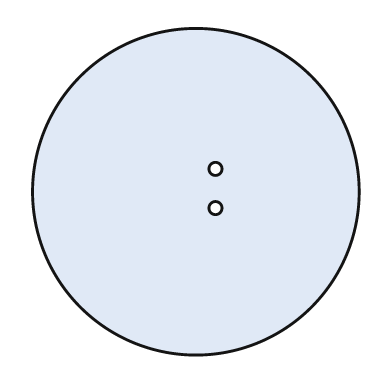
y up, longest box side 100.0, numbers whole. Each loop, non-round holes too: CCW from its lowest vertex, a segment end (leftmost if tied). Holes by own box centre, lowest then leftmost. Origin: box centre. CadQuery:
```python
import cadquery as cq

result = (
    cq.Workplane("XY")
    .moveTo(0.0, 0.0)
    .circle(50.0)
    .moveTo(6.0, -5.0)
    .circle(2.0)
    .moveTo(6.0, 7.0)
    .circle(2.0)
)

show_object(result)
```